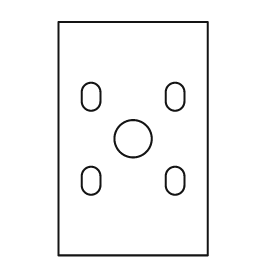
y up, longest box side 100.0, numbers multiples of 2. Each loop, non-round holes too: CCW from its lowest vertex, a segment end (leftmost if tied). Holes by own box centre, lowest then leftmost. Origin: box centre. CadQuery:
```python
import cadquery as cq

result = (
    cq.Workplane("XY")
    .moveTo(-32.0, -50.0)
    .lineTo(32.0, -50.0)
    .lineTo(32.0, 50.0)
    .lineTo(-32.0, 50.0)
    .close()
    .moveTo(-22.0, -20.0)
    .threePointArc((-18.0, -24.0), (-14.0, -20.0))
    .lineTo(-14.0, -16.0)
    .threePointArc((-18.0, -12.0), (-22.0, -16.0))
    .close()
    .moveTo(14.0, -20.0)
    .threePointArc((18.0, -24.0), (22.0, -20.0))
    .lineTo(22.0, -16.0)
    .threePointArc((18.0, -12.0), (14.0, -16.0))
    .close()
    .moveTo(0.0, 0.0)
    .circle(8.0)
    .moveTo(-22.0, 16.0)
    .threePointArc((-18.0, 12.0), (-14.0, 16.0))
    .lineTo(-14.0, 20.0)
    .threePointArc((-18.0, 24.0), (-22.0, 20.0))
    .close()
    .moveTo(14.0, 16.0)
    .threePointArc((18.0, 12.0), (22.0, 16.0))
    .lineTo(22.0, 20.0)
    .threePointArc((18.0, 24.0), (14.0, 20.0))
    .close()
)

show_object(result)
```